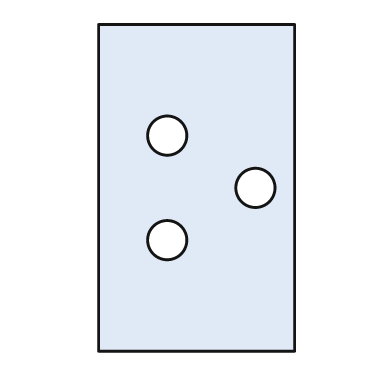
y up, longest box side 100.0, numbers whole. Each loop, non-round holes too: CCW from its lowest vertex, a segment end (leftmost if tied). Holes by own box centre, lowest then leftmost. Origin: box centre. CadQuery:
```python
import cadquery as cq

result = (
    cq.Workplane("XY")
    .moveTo(-30.0, -50.0)
    .lineTo(30.0, -50.0)
    .lineTo(30.0, 50.0)
    .lineTo(-30.0, 50.0)
    .close()
    .moveTo(-9.0, -16.0)
    .circle(6.0)
    .moveTo(18.0, 0.0)
    .circle(6.0)
    .moveTo(-9.0, 16.0)
    .circle(6.0)
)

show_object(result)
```